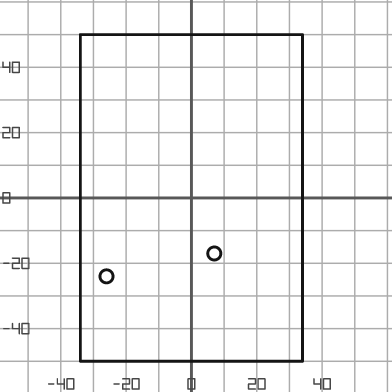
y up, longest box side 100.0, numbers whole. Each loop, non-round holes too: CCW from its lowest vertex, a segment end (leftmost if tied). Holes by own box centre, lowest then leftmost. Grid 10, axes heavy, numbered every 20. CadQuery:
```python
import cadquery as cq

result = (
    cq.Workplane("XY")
    .moveTo(-34.0, -50.0)
    .lineTo(34.0, -50.0)
    .lineTo(34.0, 50.0)
    .lineTo(-34.0, 50.0)
    .close()
    .moveTo(-26.0, -24.0)
    .circle(2.0)
    .moveTo(7.0, -17.0)
    .circle(2.0)
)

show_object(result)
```